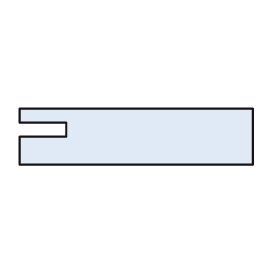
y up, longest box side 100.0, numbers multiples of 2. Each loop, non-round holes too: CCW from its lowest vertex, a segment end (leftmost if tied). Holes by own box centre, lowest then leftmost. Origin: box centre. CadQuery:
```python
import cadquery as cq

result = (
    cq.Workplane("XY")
    .moveTo(-50.0, -12.0)
    .lineTo(50.0, -12.0)
    .lineTo(50.0, 12.0)
    .lineTo(-50.0, 12.0)
    .lineTo(-50.0, 6.0)
    .lineTo(-30.0, 6.0)
    .lineTo(-30.0, 0.0)
    .lineTo(-50.0, 0.0)
    .close()
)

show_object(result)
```